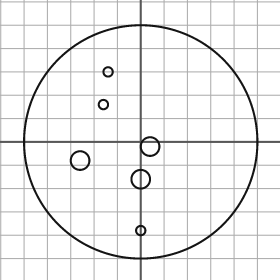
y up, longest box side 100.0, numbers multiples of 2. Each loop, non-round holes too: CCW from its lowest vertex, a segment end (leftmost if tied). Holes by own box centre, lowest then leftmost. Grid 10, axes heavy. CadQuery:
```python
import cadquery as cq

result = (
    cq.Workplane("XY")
    .moveTo(0.0, 0.0)
    .circle(50.0)
    .moveTo(0.0, -38.0)
    .circle(2.0)
    .moveTo(0.0, -16.0)
    .circle(4.0)
    .moveTo(-26.0, -8.0)
    .circle(4.0)
    .moveTo(4.0, -2.0)
    .circle(4.0)
    .moveTo(-16.0, 16.0)
    .circle(2.0)
    .moveTo(-14.0, 30.0)
    .circle(2.0)
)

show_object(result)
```